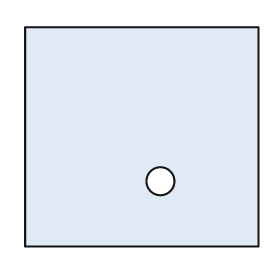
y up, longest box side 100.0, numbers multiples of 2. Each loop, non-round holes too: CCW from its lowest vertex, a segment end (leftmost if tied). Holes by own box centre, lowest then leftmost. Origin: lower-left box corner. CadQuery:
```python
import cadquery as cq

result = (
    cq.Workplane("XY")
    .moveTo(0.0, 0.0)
    .lineTo(100.0, 0.0)
    .lineTo(100.0, 94.0)
    .lineTo(0.0, 94.0)
    .close()
    .moveTo(58.0, 28.0)
    .circle(6.0)
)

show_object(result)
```